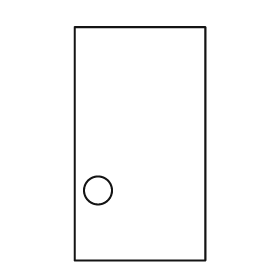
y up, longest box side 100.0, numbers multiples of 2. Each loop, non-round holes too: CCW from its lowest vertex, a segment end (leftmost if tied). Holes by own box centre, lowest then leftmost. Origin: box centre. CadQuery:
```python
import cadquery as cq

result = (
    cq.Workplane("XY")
    .moveTo(-28.0, -50.0)
    .lineTo(28.0, -50.0)
    .lineTo(28.0, 50.0)
    .lineTo(-28.0, 50.0)
    .close()
    .moveTo(-18.0, -20.0)
    .circle(6.0)
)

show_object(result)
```